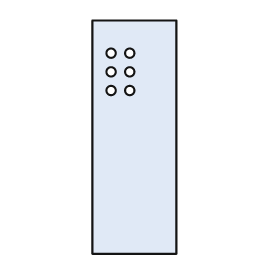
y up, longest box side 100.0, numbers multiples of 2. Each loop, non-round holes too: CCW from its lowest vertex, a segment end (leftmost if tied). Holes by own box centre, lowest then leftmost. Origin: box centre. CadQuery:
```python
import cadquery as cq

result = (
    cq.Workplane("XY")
    .moveTo(-18.0, -50.0)
    .lineTo(18.0, -50.0)
    .lineTo(18.0, 50.0)
    .lineTo(-18.0, 50.0)
    .close()
    .moveTo(-10.0, 20.0)
    .circle(2.0)
    .moveTo(-2.0, 20.0)
    .circle(2.0)
    .moveTo(-10.0, 28.0)
    .circle(2.0)
    .moveTo(-2.0, 28.0)
    .circle(2.0)
    .moveTo(-10.0, 36.0)
    .circle(2.0)
    .moveTo(-2.0, 36.0)
    .circle(2.0)
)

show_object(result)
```